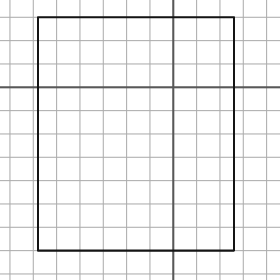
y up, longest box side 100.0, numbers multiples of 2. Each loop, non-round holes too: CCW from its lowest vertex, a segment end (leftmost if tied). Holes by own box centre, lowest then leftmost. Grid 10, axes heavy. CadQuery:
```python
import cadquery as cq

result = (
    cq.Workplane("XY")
    .moveTo(-58.0, -70.0)
    .lineTo(26.0, -70.0)
    .lineTo(26.0, 30.0)
    .lineTo(-58.0, 30.0)
    .close()
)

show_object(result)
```